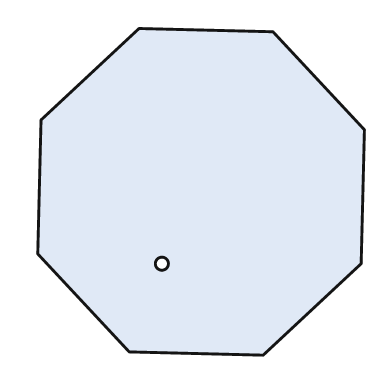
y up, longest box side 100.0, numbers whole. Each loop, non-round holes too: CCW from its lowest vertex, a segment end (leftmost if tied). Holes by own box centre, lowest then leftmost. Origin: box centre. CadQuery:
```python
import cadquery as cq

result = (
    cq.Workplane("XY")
    .moveTo(19.0, -50.0)
    .lineTo(49.0, -22.0)
    .lineTo(50.0, 19.0)
    .lineTo(22.0, 49.0)
    .lineTo(-19.0, 50.0)
    .lineTo(-49.0, 22.0)
    .lineTo(-50.0, -19.0)
    .lineTo(-22.0, -49.0)
    .close()
    .moveTo(-12.0, -22.0)
    .circle(2.0)
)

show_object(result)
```